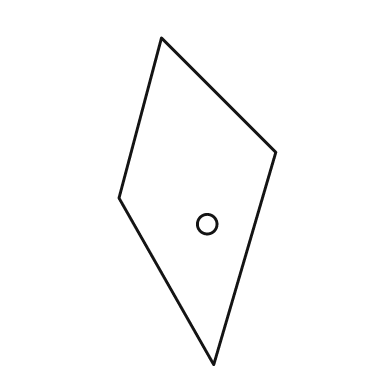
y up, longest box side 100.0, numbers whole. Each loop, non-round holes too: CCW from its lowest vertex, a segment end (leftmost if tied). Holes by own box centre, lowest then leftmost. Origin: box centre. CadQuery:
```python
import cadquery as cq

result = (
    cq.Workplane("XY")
    .moveTo(5.0, -50.0)
    .lineTo(24.0, 15.0)
    .lineTo(-11.0, 50.0)
    .lineTo(-24.0, 1.0)
    .close()
    .moveTo(3.0, -7.0)
    .circle(3.0)
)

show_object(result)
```